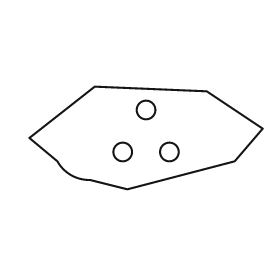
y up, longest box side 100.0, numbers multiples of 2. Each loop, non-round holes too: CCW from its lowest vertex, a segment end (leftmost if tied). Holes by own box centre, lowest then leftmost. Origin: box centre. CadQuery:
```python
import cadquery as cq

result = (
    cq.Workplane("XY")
    .moveTo(-8.0, -22.0)
    .lineTo(38.0, -10.0)
    .lineTo(50.0, 4.0)
    .lineTo(26.0, 20.0)
    .lineTo(-22.0, 22.0)
    .lineTo(-50.0, 0.0)
    .lineTo(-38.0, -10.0)
    .threePointArc((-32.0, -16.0), (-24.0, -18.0))
    .close()
    .moveTo(-10.0, -6.0)
    .circle(4.0)
    .moveTo(10.0, -6.0)
    .circle(4.0)
    .moveTo(0.0, 12.0)
    .circle(4.0)
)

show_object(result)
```